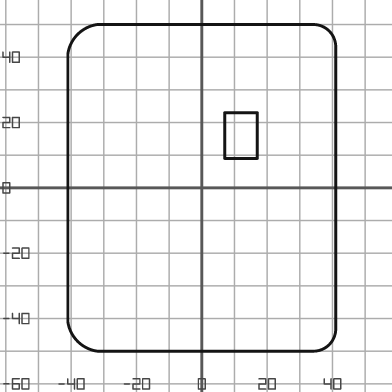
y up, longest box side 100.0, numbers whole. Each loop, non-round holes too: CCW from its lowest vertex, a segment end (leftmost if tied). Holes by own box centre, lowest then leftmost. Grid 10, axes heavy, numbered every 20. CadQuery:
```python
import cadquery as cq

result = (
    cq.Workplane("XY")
    .moveTo(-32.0, -50.0)
    .lineTo(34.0, -50.0)
    .threePointArc((39.0, -48.0), (41.0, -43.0))
    .lineTo(41.0, 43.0)
    .threePointArc((39.0, 48.0), (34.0, 50.0))
    .lineTo(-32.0, 50.0)
    .threePointArc((-38.0, 47.0), (-41.0, 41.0))
    .lineTo(-41.0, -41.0)
    .threePointArc((-38.0, -47.0), (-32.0, -50.0))
    .close()
    .moveTo(7.0, 9.0)
    .lineTo(17.0, 9.0)
    .lineTo(17.0, 23.0)
    .lineTo(7.0, 23.0)
    .close()
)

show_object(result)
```